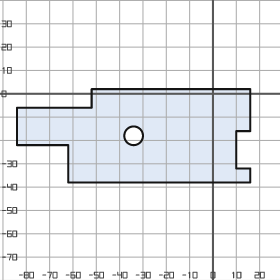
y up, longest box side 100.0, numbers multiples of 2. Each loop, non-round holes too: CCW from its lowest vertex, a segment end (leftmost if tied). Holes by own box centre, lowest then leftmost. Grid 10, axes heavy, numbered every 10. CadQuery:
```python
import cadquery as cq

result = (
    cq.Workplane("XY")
    .moveTo(-62.0, -38.0)
    .lineTo(16.0, -38.0)
    .lineTo(16.0, -32.0)
    .lineTo(10.0, -32.0)
    .lineTo(10.0, -16.0)
    .lineTo(16.0, -16.0)
    .lineTo(16.0, 2.0)
    .lineTo(-52.0, 2.0)
    .lineTo(-52.0, -6.0)
    .lineTo(-84.0, -6.0)
    .lineTo(-84.0, -22.0)
    .lineTo(-62.0, -22.0)
    .close()
    .moveTo(-34.0, -18.0)
    .circle(4.0)
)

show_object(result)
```